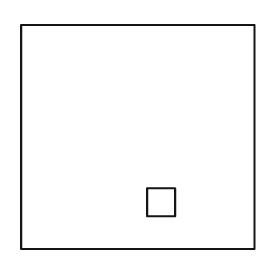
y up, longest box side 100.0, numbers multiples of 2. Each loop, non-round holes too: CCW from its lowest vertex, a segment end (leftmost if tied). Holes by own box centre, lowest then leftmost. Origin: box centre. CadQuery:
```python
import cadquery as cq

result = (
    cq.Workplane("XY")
    .moveTo(-50.0, -48.0)
    .lineTo(50.0, -48.0)
    .lineTo(50.0, 48.0)
    .lineTo(-50.0, 48.0)
    .close()
    .moveTo(4.0, -34.0)
    .lineTo(16.0, -34.0)
    .lineTo(16.0, -22.0)
    .lineTo(4.0, -22.0)
    .close()
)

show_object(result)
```